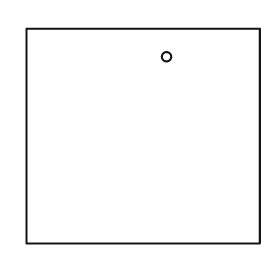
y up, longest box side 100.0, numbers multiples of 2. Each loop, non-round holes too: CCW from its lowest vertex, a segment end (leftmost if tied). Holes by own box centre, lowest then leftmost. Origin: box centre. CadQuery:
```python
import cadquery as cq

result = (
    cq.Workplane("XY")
    .moveTo(-50.0, -46.0)
    .lineTo(50.0, -46.0)
    .lineTo(50.0, 46.0)
    .lineTo(-50.0, 46.0)
    .close()
    .moveTo(10.0, 34.0)
    .circle(2.0)
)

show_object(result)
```